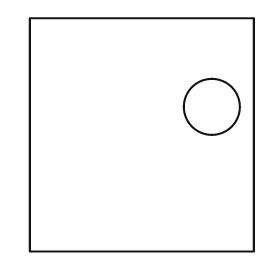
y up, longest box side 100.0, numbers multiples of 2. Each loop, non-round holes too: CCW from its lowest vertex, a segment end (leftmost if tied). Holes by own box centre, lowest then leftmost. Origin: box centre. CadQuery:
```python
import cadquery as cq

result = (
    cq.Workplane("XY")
    .moveTo(-48.0, -50.0)
    .lineTo(48.0, -50.0)
    .lineTo(48.0, 50.0)
    .lineTo(-48.0, 50.0)
    .close()
    .moveTo(30.0, 12.0)
    .circle(12.0)
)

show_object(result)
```